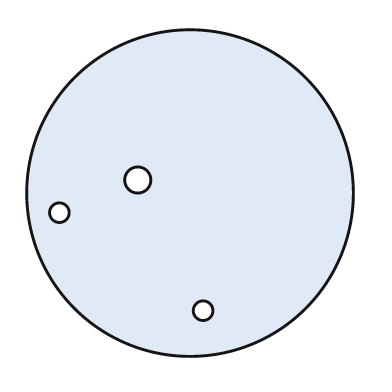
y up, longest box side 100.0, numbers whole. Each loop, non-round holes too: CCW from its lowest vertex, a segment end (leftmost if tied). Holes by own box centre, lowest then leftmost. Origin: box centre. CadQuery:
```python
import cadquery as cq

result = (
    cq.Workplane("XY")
    .moveTo(0.0, 0.0)
    .circle(50.0)
    .moveTo(4.0, -36.0)
    .circle(3.0)
    .moveTo(-40.0, -6.0)
    .circle(3.0)
    .moveTo(-16.0, 4.0)
    .circle(4.0)
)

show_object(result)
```